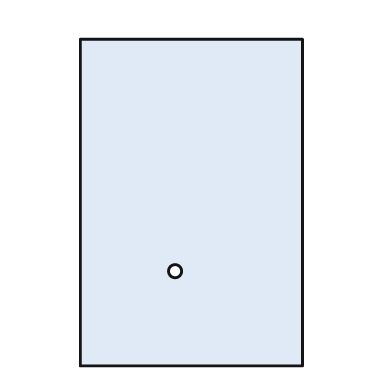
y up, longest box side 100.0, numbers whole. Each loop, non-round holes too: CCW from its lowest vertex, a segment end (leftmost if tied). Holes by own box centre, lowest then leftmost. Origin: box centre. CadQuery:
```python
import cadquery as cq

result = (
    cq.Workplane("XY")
    .moveTo(-34.0, -50.0)
    .lineTo(34.0, -50.0)
    .lineTo(34.0, 50.0)
    .lineTo(-34.0, 50.0)
    .close()
    .moveTo(-5.0, -21.0)
    .circle(2.0)
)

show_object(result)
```